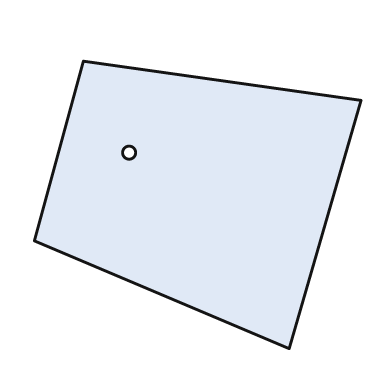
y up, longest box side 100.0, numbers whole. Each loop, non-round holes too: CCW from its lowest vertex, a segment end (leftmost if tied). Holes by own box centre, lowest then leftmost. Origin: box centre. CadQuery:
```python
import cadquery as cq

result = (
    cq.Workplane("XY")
    .moveTo(28.0, -44.0)
    .lineTo(50.0, 32.0)
    .lineTo(-35.0, 44.0)
    .lineTo(-50.0, -11.0)
    .close()
    .moveTo(-21.0, 16.0)
    .circle(2.0)
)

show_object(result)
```